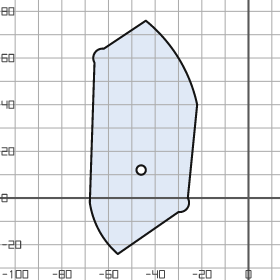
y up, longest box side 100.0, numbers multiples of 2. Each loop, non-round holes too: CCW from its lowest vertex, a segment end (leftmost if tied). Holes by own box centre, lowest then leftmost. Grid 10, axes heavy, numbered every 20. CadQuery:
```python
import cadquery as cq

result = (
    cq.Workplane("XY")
    .moveTo(-56.0, -24.0)
    .lineTo(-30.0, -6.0)
    .threePointArc((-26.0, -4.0), (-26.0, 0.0))
    .lineTo(-22.0, 40.0)
    .threePointArc((-30.0, 60.0), (-44.0, 76.0))
    .lineTo(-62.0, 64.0)
    .threePointArc((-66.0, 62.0), (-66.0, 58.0))
    .lineTo(-68.0, -2.0)
    .threePointArc((-64.0, -14.0), (-56.0, -24.0))
    .close()
    .moveTo(-46.0, 12.0)
    .circle(2.0)
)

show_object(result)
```